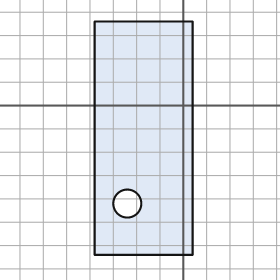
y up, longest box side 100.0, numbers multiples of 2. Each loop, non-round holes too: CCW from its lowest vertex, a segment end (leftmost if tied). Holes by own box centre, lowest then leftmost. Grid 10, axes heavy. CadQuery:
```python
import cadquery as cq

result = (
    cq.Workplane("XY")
    .moveTo(-38.0, -64.0)
    .lineTo(4.0, -64.0)
    .lineTo(4.0, 36.0)
    .lineTo(-38.0, 36.0)
    .close()
    .moveTo(-24.0, -42.0)
    .circle(6.0)
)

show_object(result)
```